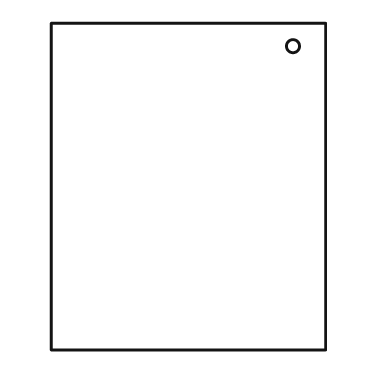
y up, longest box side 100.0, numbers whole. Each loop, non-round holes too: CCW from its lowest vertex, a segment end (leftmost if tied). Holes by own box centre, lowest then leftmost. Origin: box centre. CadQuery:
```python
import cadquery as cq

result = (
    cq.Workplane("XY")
    .moveTo(-42.0, -50.0)
    .lineTo(42.0, -50.0)
    .lineTo(42.0, 50.0)
    .lineTo(-42.0, 50.0)
    .close()
    .moveTo(32.0, 43.0)
    .circle(2.0)
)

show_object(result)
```